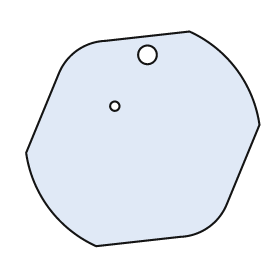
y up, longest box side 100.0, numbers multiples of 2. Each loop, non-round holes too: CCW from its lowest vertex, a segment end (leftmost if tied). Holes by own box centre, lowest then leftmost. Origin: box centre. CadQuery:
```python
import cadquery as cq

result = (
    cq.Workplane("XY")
    .moveTo(-20.0, -46.0)
    .lineTo(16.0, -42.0)
    .threePointArc((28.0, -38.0), (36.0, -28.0))
    .lineTo(50.0, 6.0)
    .threePointArc((40.0, 30.0), (20.0, 46.0))
    .lineTo(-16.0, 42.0)
    .threePointArc((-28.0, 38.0), (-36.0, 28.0))
    .lineTo(-50.0, -6.0)
    .threePointArc((-40.0, -30.0), (-20.0, -46.0))
    .close()
    .moveTo(-12.0, 14.0)
    .circle(2.0)
    .moveTo(2.0, 36.0)
    .circle(4.0)
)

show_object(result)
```